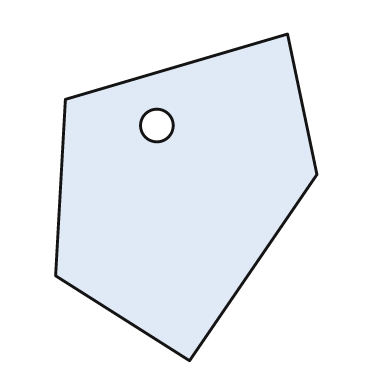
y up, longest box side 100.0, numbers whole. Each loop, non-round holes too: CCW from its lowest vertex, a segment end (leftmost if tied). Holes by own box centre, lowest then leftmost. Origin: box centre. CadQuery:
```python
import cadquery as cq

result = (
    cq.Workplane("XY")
    .moveTo(1.0, -50.0)
    .lineTo(40.0, 7.0)
    .lineTo(31.0, 50.0)
    .lineTo(-37.0, 30.0)
    .lineTo(-40.0, -24.0)
    .close()
    .moveTo(-9.0, 22.0)
    .circle(5.0)
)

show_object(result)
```